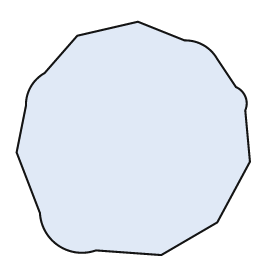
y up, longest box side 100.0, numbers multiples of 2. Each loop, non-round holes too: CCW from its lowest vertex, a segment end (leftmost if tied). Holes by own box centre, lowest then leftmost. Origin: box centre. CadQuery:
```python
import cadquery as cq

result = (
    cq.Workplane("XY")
    .moveTo(12.0, -50.0)
    .lineTo(36.0, -36.0)
    .lineTo(50.0, -10.0)
    .lineTo(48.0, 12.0)
    .threePointArc((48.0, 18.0), (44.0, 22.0))
    .lineTo(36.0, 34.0)
    .threePointArc((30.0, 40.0), (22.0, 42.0))
    .lineTo(2.0, 50.0)
    .lineTo(-24.0, 44.0)
    .lineTo(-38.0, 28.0)
    .threePointArc((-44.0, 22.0), (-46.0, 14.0))
    .lineTo(-50.0, -6.0)
    .lineTo(-40.0, -32.0)
    .threePointArc((-32.0, -46.0), (-16.0, -48.0))
    .close()
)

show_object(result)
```